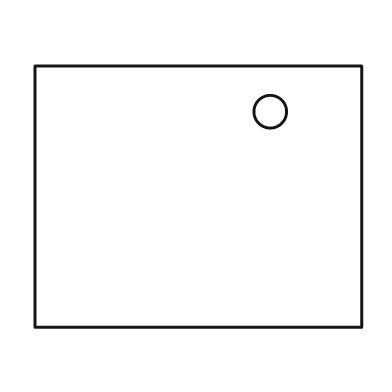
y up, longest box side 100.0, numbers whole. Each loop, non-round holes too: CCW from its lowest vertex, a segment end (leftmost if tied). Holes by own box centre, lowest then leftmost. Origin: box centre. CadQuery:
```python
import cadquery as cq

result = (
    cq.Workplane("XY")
    .moveTo(-50.0, -40.0)
    .lineTo(50.0, -40.0)
    .lineTo(50.0, 40.0)
    .lineTo(-50.0, 40.0)
    .close()
    .moveTo(22.0, 26.0)
    .circle(5.0)
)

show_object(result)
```